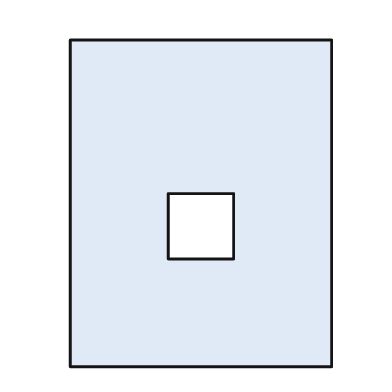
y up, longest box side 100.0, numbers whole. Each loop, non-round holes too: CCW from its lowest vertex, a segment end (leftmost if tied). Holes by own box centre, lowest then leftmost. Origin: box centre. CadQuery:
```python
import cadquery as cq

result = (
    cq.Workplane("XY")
    .moveTo(-40.0, -50.0)
    .lineTo(40.0, -50.0)
    .lineTo(40.0, 50.0)
    .lineTo(-40.0, 50.0)
    .close()
    .moveTo(-10.0, -17.0)
    .lineTo(10.0, -17.0)
    .lineTo(10.0, 3.0)
    .lineTo(-10.0, 3.0)
    .close()
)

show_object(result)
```